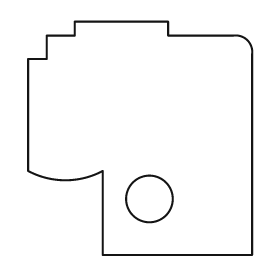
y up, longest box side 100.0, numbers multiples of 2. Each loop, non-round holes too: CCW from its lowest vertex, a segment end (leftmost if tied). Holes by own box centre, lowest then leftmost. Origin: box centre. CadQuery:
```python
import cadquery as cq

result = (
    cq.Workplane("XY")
    .moveTo(-16.0, -50.0)
    .lineTo(48.0, -50.0)
    .lineTo(48.0, 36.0)
    .threePointArc((46.0, 42.0), (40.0, 44.0))
    .lineTo(12.0, 44.0)
    .lineTo(12.0, 50.0)
    .lineTo(-28.0, 50.0)
    .lineTo(-28.0, 44.0)
    .lineTo(-40.0, 44.0)
    .lineTo(-40.0, 34.0)
    .lineTo(-48.0, 34.0)
    .lineTo(-48.0, -14.0)
    .threePointArc((-32.0, -18.0), (-16.0, -14.0))
    .close()
    .moveTo(4.0, -26.0)
    .circle(10.0)
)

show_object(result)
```